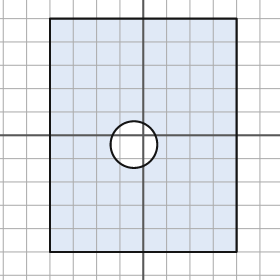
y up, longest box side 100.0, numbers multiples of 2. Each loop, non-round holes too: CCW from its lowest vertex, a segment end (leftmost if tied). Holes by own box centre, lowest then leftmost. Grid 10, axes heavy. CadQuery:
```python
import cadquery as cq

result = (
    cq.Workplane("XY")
    .moveTo(-40.0, -50.0)
    .lineTo(40.0, -50.0)
    .lineTo(40.0, 50.0)
    .lineTo(-40.0, 50.0)
    .close()
    .moveTo(-4.0, -4.0)
    .circle(10.0)
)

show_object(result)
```